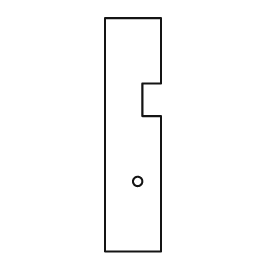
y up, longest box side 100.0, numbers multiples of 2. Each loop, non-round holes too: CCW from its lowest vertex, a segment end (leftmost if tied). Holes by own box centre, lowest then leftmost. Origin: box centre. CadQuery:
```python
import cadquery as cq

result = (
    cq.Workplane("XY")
    .moveTo(-12.0, -50.0)
    .lineTo(12.0, -50.0)
    .lineTo(12.0, 8.0)
    .lineTo(4.0, 8.0)
    .lineTo(4.0, 22.0)
    .lineTo(12.0, 22.0)
    .lineTo(12.0, 50.0)
    .lineTo(-12.0, 50.0)
    .close()
    .moveTo(2.0, -20.0)
    .circle(2.0)
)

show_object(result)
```